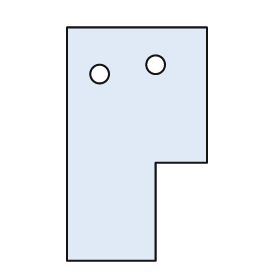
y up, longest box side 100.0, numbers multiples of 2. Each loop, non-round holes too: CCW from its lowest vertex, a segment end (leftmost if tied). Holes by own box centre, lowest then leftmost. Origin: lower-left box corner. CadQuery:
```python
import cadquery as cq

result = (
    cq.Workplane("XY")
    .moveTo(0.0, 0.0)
    .lineTo(38.0, 0.0)
    .lineTo(38.0, 42.0)
    .lineTo(60.0, 42.0)
    .lineTo(60.0, 100.0)
    .lineTo(0.0, 100.0)
    .close()
    .moveTo(14.0, 80.0)
    .circle(4.0)
    .moveTo(38.0, 84.0)
    .circle(4.0)
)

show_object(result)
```